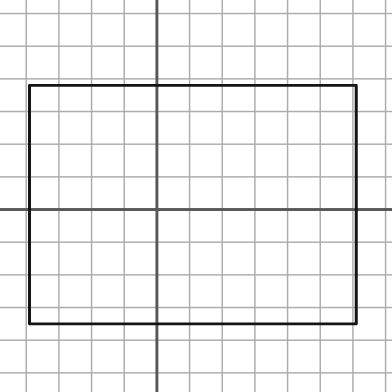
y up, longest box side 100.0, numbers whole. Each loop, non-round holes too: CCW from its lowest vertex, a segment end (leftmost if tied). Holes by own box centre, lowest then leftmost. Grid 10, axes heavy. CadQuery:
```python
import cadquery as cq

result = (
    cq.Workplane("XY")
    .moveTo(-39.0, -35.0)
    .lineTo(61.0, -35.0)
    .lineTo(61.0, 38.0)
    .lineTo(-39.0, 38.0)
    .close()
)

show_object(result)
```